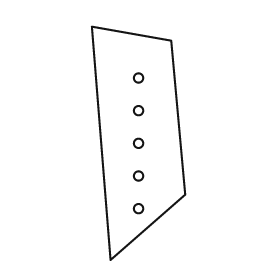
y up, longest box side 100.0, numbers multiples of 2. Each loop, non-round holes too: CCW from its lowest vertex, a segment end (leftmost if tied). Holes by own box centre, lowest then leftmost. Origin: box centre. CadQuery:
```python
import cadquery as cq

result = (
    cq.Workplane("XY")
    .moveTo(-12.0, -50.0)
    .lineTo(20.0, -22.0)
    .lineTo(14.0, 44.0)
    .lineTo(-20.0, 50.0)
    .close()
    .moveTo(0.0, -28.0)
    .circle(2.0)
    .moveTo(0.0, -14.0)
    .circle(2.0)
    .moveTo(0.0, 0.0)
    .circle(2.0)
    .moveTo(0.0, 14.0)
    .circle(2.0)
    .moveTo(0.0, 28.0)
    .circle(2.0)
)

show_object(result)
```